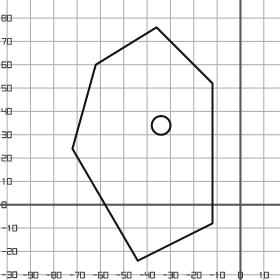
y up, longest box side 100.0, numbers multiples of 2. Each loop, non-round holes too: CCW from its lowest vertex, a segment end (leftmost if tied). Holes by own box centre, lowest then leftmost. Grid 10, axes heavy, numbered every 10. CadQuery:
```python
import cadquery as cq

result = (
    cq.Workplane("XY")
    .moveTo(-44.0, -24.0)
    .lineTo(-12.0, -8.0)
    .lineTo(-12.0, 52.0)
    .lineTo(-36.0, 76.0)
    .lineTo(-62.0, 60.0)
    .lineTo(-72.0, 24.0)
    .close()
    .moveTo(-34.0, 34.0)
    .circle(4.0)
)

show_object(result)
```